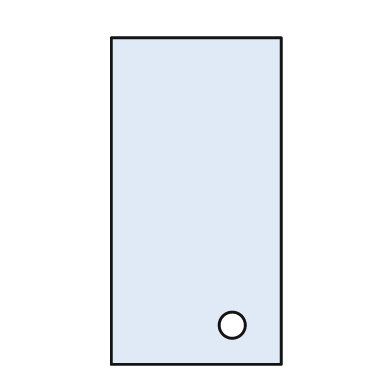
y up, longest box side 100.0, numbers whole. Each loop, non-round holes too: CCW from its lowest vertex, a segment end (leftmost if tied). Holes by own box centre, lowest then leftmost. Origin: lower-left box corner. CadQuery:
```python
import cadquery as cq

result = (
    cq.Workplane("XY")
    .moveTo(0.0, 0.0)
    .lineTo(52.0, 0.0)
    .lineTo(52.0, 100.0)
    .lineTo(0.0, 100.0)
    .close()
    .moveTo(37.0, 12.0)
    .circle(4.0)
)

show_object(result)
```